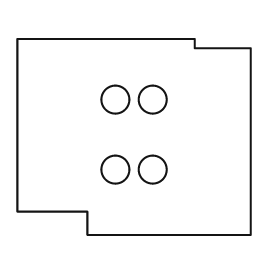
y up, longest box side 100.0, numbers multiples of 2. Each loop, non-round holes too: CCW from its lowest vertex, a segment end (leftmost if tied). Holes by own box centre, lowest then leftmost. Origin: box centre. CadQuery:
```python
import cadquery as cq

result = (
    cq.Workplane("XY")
    .moveTo(-20.0, -42.0)
    .lineTo(50.0, -42.0)
    .lineTo(50.0, 38.0)
    .lineTo(26.0, 38.0)
    .lineTo(26.0, 42.0)
    .lineTo(-50.0, 42.0)
    .lineTo(-50.0, -32.0)
    .lineTo(-20.0, -32.0)
    .close()
    .moveTo(-8.0, -14.0)
    .circle(6.0)
    .moveTo(8.0, -14.0)
    .circle(6.0)
    .moveTo(-8.0, 16.0)
    .circle(6.0)
    .moveTo(8.0, 16.0)
    .circle(6.0)
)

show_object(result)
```